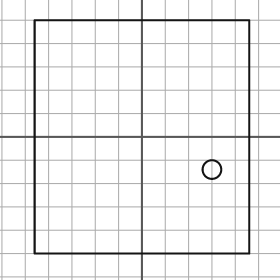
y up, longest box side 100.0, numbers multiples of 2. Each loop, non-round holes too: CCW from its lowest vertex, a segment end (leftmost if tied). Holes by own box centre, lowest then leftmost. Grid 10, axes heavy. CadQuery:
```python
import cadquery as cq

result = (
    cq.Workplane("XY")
    .moveTo(-46.0, -50.0)
    .lineTo(46.0, -50.0)
    .lineTo(46.0, 50.0)
    .lineTo(-46.0, 50.0)
    .close()
    .moveTo(30.0, -14.0)
    .circle(4.0)
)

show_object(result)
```